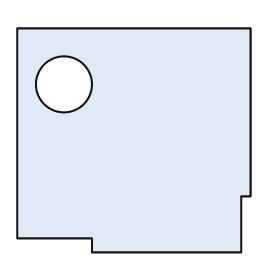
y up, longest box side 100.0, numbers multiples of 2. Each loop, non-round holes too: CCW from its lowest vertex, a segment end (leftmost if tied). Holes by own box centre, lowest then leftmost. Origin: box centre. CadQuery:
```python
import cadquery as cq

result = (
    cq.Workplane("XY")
    .moveTo(-18.0, -48.0)
    .lineTo(46.0, -48.0)
    .lineTo(46.0, -24.0)
    .lineTo(50.0, -24.0)
    .lineTo(50.0, 48.0)
    .lineTo(-50.0, 48.0)
    .lineTo(-50.0, -42.0)
    .lineTo(-18.0, -42.0)
    .close()
    .moveTo(-30.0, 24.0)
    .circle(12.0)
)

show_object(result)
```